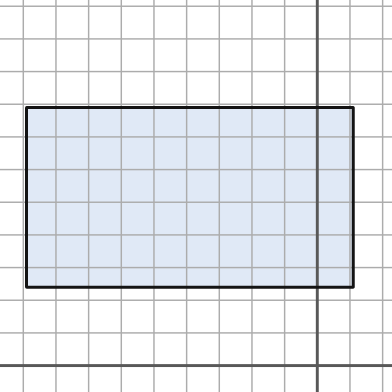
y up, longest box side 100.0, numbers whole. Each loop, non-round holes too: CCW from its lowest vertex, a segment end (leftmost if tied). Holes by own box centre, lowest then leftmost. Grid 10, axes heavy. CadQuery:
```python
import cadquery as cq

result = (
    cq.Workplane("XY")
    .moveTo(-89.0, 24.0)
    .lineTo(11.0, 24.0)
    .lineTo(11.0, 79.0)
    .lineTo(-89.0, 79.0)
    .close()
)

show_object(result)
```